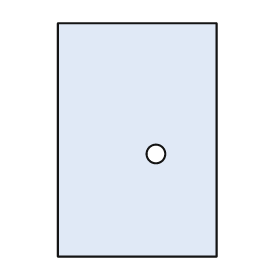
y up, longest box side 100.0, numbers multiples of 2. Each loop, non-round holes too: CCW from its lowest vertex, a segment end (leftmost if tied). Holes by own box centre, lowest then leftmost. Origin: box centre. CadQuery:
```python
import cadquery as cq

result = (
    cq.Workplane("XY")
    .moveTo(-34.0, -50.0)
    .lineTo(34.0, -50.0)
    .lineTo(34.0, 50.0)
    .lineTo(-34.0, 50.0)
    .close()
    .moveTo(8.0, -6.0)
    .circle(4.0)
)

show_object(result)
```